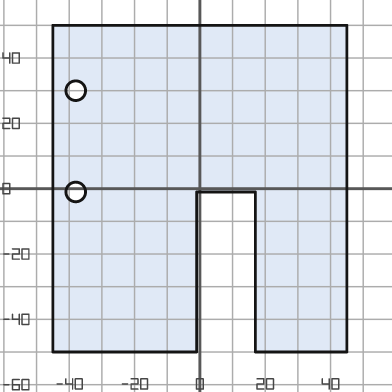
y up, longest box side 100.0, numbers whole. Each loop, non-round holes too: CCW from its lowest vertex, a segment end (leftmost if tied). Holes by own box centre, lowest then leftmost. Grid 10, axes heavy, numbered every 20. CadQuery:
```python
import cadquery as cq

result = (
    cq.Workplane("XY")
    .moveTo(-45.0, -50.0)
    .lineTo(-1.0, -50.0)
    .lineTo(-1.0, -1.0)
    .lineTo(17.0, -1.0)
    .lineTo(17.0, -50.0)
    .lineTo(45.0, -50.0)
    .lineTo(45.0, 50.0)
    .lineTo(-45.0, 50.0)
    .close()
    .moveTo(-38.0, -1.0)
    .circle(3.0)
    .moveTo(-38.0, 30.0)
    .circle(3.0)
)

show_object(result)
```